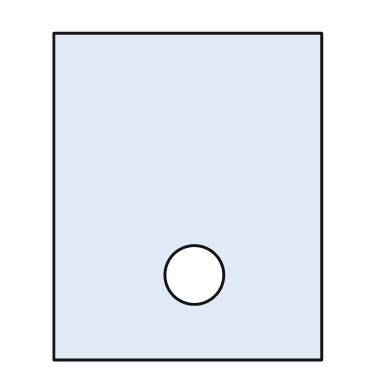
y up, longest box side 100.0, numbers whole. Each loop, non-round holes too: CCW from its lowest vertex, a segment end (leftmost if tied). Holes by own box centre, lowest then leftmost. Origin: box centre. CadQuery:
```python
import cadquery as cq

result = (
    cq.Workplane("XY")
    .moveTo(-41.0, -50.0)
    .lineTo(41.0, -50.0)
    .lineTo(41.0, 50.0)
    .lineTo(-41.0, 50.0)
    .close()
    .moveTo(2.0, -24.0)
    .circle(9.0)
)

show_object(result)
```